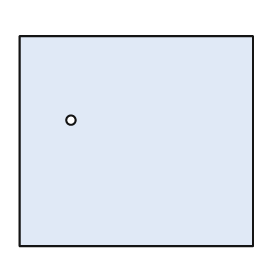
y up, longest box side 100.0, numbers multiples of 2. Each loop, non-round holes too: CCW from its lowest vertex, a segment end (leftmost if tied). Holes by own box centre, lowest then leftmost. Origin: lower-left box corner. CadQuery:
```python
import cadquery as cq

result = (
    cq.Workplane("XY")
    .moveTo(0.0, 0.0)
    .lineTo(100.0, 0.0)
    .lineTo(100.0, 90.0)
    .lineTo(0.0, 90.0)
    .close()
    .moveTo(22.0, 54.0)
    .circle(2.0)
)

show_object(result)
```